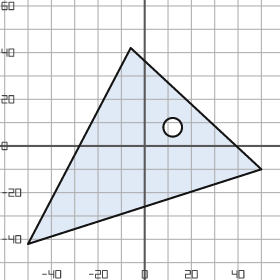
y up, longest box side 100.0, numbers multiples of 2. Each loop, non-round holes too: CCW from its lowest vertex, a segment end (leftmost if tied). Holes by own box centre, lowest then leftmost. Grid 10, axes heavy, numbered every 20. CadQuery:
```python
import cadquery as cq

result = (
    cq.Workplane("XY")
    .moveTo(-50.0, -42.0)
    .lineTo(50.0, -10.0)
    .lineTo(-6.0, 42.0)
    .close()
    .moveTo(12.0, 8.0)
    .circle(4.0)
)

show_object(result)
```